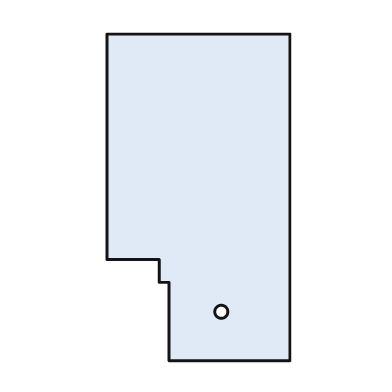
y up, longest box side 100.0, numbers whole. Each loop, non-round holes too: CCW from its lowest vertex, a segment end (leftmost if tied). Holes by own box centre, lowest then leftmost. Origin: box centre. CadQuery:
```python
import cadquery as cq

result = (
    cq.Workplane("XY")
    .moveTo(-9.0, -50.0)
    .lineTo(28.0, -50.0)
    .lineTo(28.0, 50.0)
    .lineTo(-28.0, 50.0)
    .lineTo(-28.0, -19.0)
    .lineTo(-12.0, -19.0)
    .lineTo(-12.0, -26.0)
    .lineTo(-9.0, -26.0)
    .close()
    .moveTo(7.0, -35.0)
    .circle(2.0)
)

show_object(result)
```